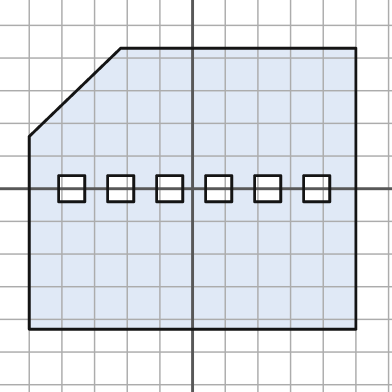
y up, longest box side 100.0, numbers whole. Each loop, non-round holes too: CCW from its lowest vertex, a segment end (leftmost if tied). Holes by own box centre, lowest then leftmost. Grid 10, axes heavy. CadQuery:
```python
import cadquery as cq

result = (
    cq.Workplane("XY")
    .moveTo(-50.0, -43.0)
    .lineTo(50.0, -43.0)
    .lineTo(50.0, 43.0)
    .lineTo(-22.0, 43.0)
    .lineTo(-50.0, 16.0)
    .close()
    .moveTo(-41.0, -4.0)
    .lineTo(-33.0, -4.0)
    .lineTo(-33.0, 4.0)
    .lineTo(-41.0, 4.0)
    .close()
    .moveTo(-26.0, -4.0)
    .lineTo(-18.0, -4.0)
    .lineTo(-18.0, 4.0)
    .lineTo(-26.0, 4.0)
    .close()
    .moveTo(-11.0, -4.0)
    .lineTo(-3.0, -4.0)
    .lineTo(-3.0, 4.0)
    .lineTo(-11.0, 4.0)
    .close()
    .moveTo(4.0, -4.0)
    .lineTo(12.0, -4.0)
    .lineTo(12.0, 4.0)
    .lineTo(4.0, 4.0)
    .close()
    .moveTo(19.0, -4.0)
    .lineTo(27.0, -4.0)
    .lineTo(27.0, 4.0)
    .lineTo(19.0, 4.0)
    .close()
    .moveTo(34.0, -4.0)
    .lineTo(42.0, -4.0)
    .lineTo(42.0, 4.0)
    .lineTo(34.0, 4.0)
    .close()
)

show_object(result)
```